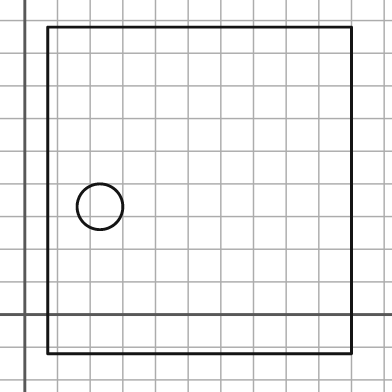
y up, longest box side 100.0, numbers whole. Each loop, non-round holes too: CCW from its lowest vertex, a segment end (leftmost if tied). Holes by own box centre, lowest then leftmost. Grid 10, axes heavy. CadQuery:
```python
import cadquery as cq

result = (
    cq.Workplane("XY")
    .moveTo(7.0, -12.0)
    .lineTo(100.0, -12.0)
    .lineTo(100.0, 88.0)
    .lineTo(7.0, 88.0)
    .close()
    .moveTo(23.0, 33.0)
    .circle(7.0)
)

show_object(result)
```